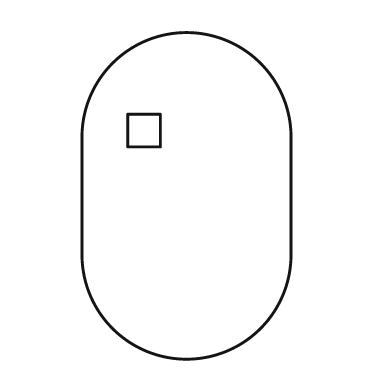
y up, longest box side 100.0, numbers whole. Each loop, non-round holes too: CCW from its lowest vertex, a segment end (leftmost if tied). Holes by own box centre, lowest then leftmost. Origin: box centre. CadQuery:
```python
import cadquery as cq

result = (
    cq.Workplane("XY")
    .moveTo(-32.0, -18.0)
    .threePointArc((0.0, -50.0), (32.0, -18.0))
    .lineTo(32.0, 18.0)
    .threePointArc((0.0, 50.0), (-32.0, 18.0))
    .close()
    .moveTo(-18.0, 15.0)
    .lineTo(-8.0, 15.0)
    .lineTo(-8.0, 25.0)
    .lineTo(-18.0, 25.0)
    .close()
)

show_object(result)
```